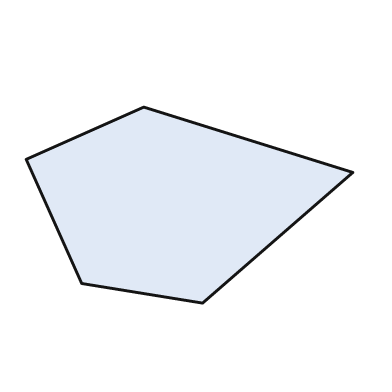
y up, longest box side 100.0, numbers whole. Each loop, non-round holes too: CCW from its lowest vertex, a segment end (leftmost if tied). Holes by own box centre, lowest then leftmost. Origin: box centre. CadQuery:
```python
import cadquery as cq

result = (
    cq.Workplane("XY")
    .moveTo(4.0, -30.0)
    .lineTo(50.0, 10.0)
    .lineTo(-14.0, 30.0)
    .lineTo(-50.0, 14.0)
    .lineTo(-33.0, -24.0)
    .close()
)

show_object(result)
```